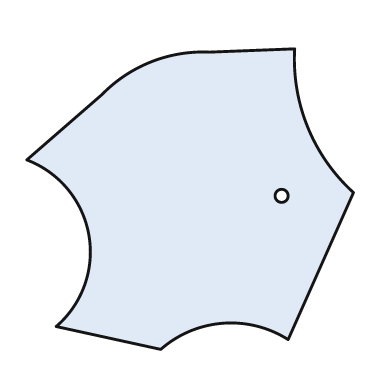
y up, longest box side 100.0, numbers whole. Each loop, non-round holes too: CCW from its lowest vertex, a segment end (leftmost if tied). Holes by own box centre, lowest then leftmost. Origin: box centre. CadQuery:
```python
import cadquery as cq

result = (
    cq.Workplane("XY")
    .moveTo(-9.0, -46.0)
    .threePointArc((10.0, -38.0), (30.0, -43.0))
    .lineTo(50.0, 2.0)
    .threePointArc((36.0, 22.0), (32.0, 46.0))
    .lineTo(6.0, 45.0)
    .threePointArc((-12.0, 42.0), (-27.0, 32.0))
    .lineTo(-50.0, 12.0)
    .threePointArc((-31.0, -11.0), (-41.0, -39.0))
    .close()
    .moveTo(28.0, 1.0)
    .circle(2.0)
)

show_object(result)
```